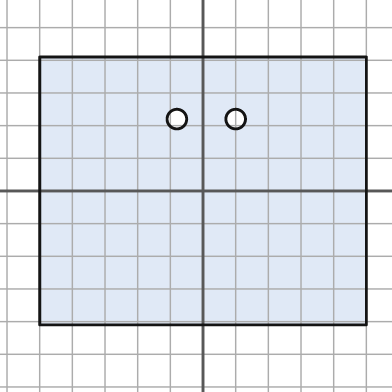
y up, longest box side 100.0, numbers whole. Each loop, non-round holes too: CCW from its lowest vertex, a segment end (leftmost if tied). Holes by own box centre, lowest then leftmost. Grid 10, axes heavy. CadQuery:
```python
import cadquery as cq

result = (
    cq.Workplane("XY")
    .moveTo(-50.0, -41.0)
    .lineTo(50.0, -41.0)
    .lineTo(50.0, 41.0)
    .lineTo(-50.0, 41.0)
    .close()
    .moveTo(-8.0, 22.0)
    .circle(3.0)
    .moveTo(10.0, 22.0)
    .circle(3.0)
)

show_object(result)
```